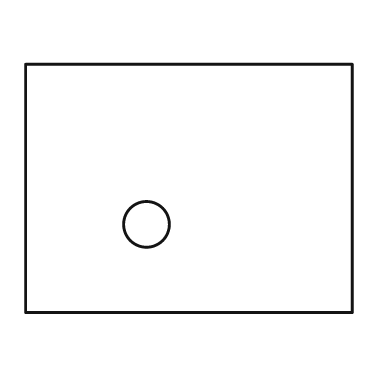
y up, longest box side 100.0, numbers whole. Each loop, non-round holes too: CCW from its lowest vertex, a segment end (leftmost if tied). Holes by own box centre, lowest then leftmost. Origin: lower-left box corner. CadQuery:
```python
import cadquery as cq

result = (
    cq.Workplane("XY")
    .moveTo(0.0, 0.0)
    .lineTo(100.0, 0.0)
    .lineTo(100.0, 76.0)
    .lineTo(0.0, 76.0)
    .close()
    .moveTo(37.0, 27.0)
    .circle(7.0)
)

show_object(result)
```